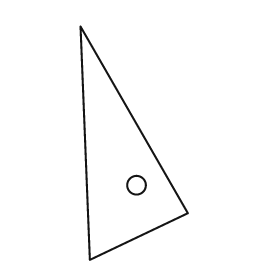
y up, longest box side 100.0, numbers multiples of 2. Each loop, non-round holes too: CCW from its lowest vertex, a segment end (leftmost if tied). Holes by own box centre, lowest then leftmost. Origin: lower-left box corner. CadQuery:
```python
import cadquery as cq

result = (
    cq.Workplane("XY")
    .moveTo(4.0, 0.0)
    .lineTo(46.0, 20.0)
    .lineTo(0.0, 100.0)
    .close()
    .moveTo(24.0, 32.0)
    .circle(4.0)
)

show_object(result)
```